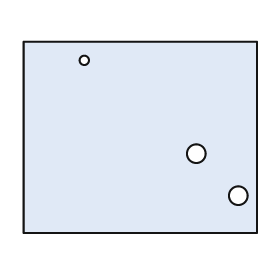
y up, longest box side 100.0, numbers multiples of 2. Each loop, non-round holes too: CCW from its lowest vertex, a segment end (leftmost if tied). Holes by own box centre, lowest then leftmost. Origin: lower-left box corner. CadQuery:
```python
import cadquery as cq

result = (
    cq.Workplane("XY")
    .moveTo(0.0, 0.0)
    .lineTo(100.0, 0.0)
    .lineTo(100.0, 82.0)
    .lineTo(0.0, 82.0)
    .close()
    .moveTo(92.0, 16.0)
    .circle(4.0)
    .moveTo(74.0, 34.0)
    .circle(4.0)
    .moveTo(26.0, 74.0)
    .circle(2.0)
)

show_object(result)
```